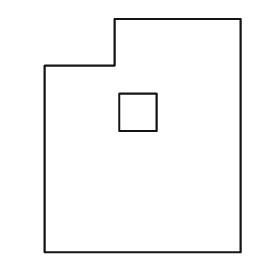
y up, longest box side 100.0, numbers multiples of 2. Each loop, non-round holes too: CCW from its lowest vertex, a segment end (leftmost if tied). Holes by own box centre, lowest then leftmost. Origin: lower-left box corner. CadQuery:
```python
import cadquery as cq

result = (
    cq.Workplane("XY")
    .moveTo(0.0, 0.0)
    .lineTo(84.0, 0.0)
    .lineTo(84.0, 100.0)
    .lineTo(30.0, 100.0)
    .lineTo(30.0, 80.0)
    .lineTo(0.0, 80.0)
    .close()
    .moveTo(32.0, 52.0)
    .lineTo(48.0, 52.0)
    .lineTo(48.0, 68.0)
    .lineTo(32.0, 68.0)
    .close()
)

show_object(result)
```